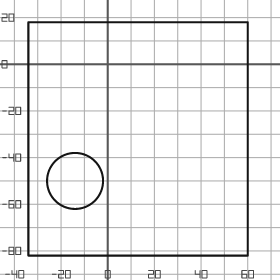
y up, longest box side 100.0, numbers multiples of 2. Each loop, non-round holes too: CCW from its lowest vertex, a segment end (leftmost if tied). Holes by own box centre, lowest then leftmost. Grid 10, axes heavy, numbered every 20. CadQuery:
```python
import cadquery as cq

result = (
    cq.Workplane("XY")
    .moveTo(-34.0, -82.0)
    .lineTo(60.0, -82.0)
    .lineTo(60.0, 18.0)
    .lineTo(-34.0, 18.0)
    .close()
    .moveTo(-14.0, -50.0)
    .circle(12.0)
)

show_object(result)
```